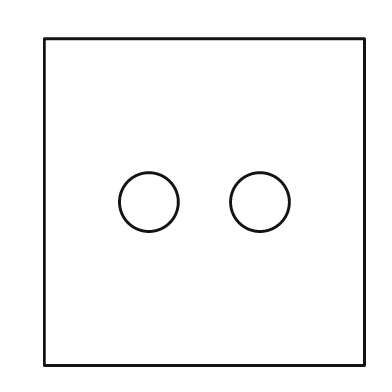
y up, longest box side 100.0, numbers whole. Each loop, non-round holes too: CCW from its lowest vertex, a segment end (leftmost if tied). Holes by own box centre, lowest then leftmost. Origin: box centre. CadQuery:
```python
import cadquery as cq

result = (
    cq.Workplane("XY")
    .moveTo(-49.0, -50.0)
    .lineTo(49.0, -50.0)
    .lineTo(49.0, 50.0)
    .lineTo(-49.0, 50.0)
    .close()
    .moveTo(-17.0, 0.0)
    .circle(9.0)
    .moveTo(17.0, 0.0)
    .circle(9.0)
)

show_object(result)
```